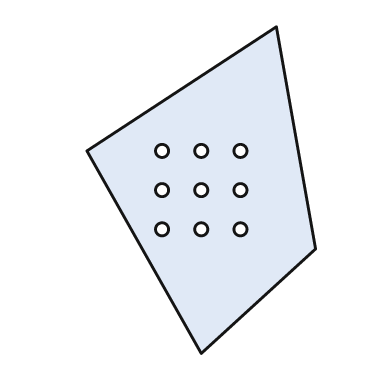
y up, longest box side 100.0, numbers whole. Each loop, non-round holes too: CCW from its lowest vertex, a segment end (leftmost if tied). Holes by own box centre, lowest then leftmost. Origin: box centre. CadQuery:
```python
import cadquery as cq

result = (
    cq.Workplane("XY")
    .moveTo(0.0, -50.0)
    .lineTo(35.0, -18.0)
    .lineTo(23.0, 50.0)
    .lineTo(-35.0, 12.0)
    .close()
    .moveTo(-12.0, -12.0)
    .circle(2.0)
    .moveTo(0.0, -12.0)
    .circle(2.0)
    .moveTo(12.0, -12.0)
    .circle(2.0)
    .moveTo(-12.0, 0.0)
    .circle(2.0)
    .moveTo(0.0, 0.0)
    .circle(2.0)
    .moveTo(12.0, 0.0)
    .circle(2.0)
    .moveTo(-12.0, 12.0)
    .circle(2.0)
    .moveTo(0.0, 12.0)
    .circle(2.0)
    .moveTo(12.0, 12.0)
    .circle(2.0)
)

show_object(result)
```